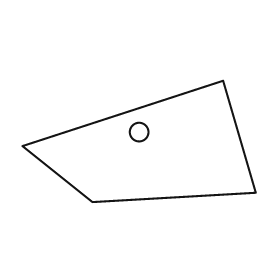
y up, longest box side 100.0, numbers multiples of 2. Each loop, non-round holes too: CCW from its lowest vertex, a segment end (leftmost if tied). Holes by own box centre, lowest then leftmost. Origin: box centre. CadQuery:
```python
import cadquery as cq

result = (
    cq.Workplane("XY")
    .moveTo(-20.0, -26.0)
    .lineTo(50.0, -22.0)
    .lineTo(36.0, 26.0)
    .lineTo(-50.0, -2.0)
    .close()
    .moveTo(0.0, 4.0)
    .circle(4.0)
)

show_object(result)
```